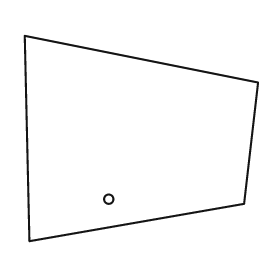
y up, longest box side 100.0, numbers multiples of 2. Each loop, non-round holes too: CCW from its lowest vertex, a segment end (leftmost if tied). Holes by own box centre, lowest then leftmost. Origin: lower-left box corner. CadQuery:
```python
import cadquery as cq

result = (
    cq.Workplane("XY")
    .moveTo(2.0, 0.0)
    .lineTo(94.0, 16.0)
    .lineTo(100.0, 68.0)
    .lineTo(0.0, 88.0)
    .close()
    .moveTo(36.0, 18.0)
    .circle(2.0)
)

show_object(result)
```